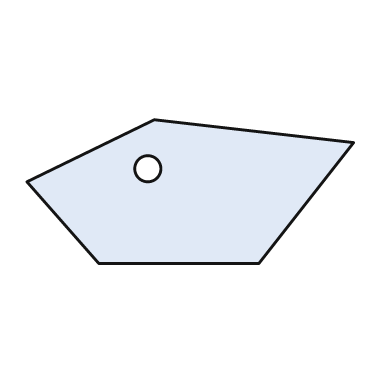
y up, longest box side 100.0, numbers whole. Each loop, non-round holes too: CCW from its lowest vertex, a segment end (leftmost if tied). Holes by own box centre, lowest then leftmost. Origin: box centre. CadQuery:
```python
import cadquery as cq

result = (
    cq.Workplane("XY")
    .moveTo(-28.0, -22.0)
    .lineTo(21.0, -22.0)
    .lineTo(50.0, 15.0)
    .lineTo(-11.0, 22.0)
    .lineTo(-50.0, 3.0)
    .close()
    .moveTo(-13.0, 7.0)
    .circle(4.0)
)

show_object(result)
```